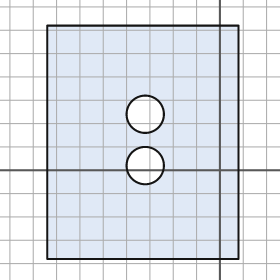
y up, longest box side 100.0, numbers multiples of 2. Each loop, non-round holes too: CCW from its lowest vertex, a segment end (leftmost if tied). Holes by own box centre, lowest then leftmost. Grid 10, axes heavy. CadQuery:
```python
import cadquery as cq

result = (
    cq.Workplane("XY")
    .moveTo(-74.0, -38.0)
    .lineTo(8.0, -38.0)
    .lineTo(8.0, 62.0)
    .lineTo(-74.0, 62.0)
    .close()
    .moveTo(-32.0, 2.0)
    .circle(8.0)
    .moveTo(-32.0, 24.0)
    .circle(8.0)
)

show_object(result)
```